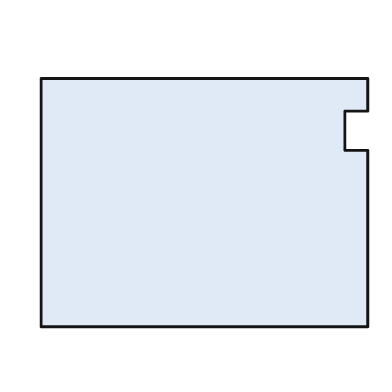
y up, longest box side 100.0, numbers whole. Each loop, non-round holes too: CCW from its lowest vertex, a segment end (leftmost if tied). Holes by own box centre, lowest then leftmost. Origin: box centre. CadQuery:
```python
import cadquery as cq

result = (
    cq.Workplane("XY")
    .moveTo(-50.0, -38.0)
    .lineTo(50.0, -38.0)
    .lineTo(50.0, 16.0)
    .lineTo(43.0, 16.0)
    .lineTo(43.0, 28.0)
    .lineTo(50.0, 28.0)
    .lineTo(50.0, 38.0)
    .lineTo(-50.0, 38.0)
    .close()
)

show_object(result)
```